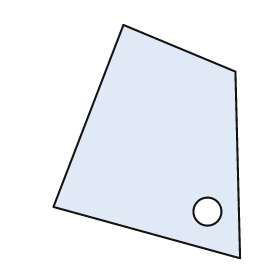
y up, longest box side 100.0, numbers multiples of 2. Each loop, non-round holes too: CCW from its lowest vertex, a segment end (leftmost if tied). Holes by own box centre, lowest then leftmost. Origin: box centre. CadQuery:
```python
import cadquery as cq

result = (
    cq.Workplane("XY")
    .moveTo(40.0, -50.0)
    .lineTo(38.0, 30.0)
    .lineTo(-10.0, 50.0)
    .lineTo(-40.0, -28.0)
    .close()
    .moveTo(26.0, -30.0)
    .circle(6.0)
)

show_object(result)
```